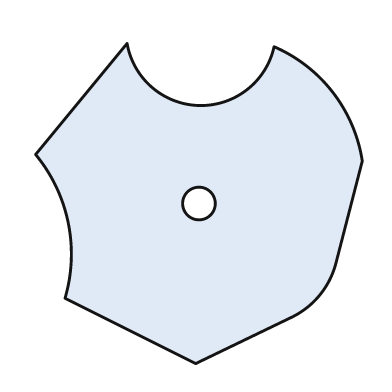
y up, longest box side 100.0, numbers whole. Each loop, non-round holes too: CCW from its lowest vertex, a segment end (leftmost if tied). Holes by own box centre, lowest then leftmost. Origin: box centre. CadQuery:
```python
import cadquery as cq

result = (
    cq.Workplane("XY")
    .moveTo(-1.0, -49.0)
    .lineTo(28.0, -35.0)
    .threePointArc((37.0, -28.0), (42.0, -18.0))
    .lineTo(50.0, 13.0)
    .threePointArc((41.0, 34.0), (23.0, 48.0))
    .threePointArc((0.0, 30.0), (-22.0, 49.0))
    .lineTo(-50.0, 15.0)
    .threePointArc((-40.0, -6.0), (-41.0, -29.0))
    .close()
    .moveTo(0.0, 0.0)
    .circle(5.0)
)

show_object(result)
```